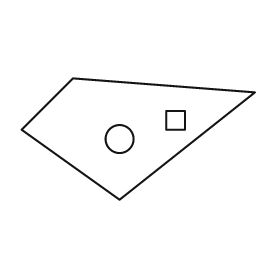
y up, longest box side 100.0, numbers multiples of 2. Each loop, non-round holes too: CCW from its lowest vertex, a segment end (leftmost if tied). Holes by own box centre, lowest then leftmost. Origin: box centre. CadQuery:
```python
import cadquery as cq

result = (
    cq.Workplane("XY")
    .moveTo(-8.0, -26.0)
    .lineTo(50.0, 20.0)
    .lineTo(-28.0, 26.0)
    .lineTo(-50.0, 4.0)
    .close()
    .moveTo(-8.0, 0.0)
    .circle(6.0)
    .moveTo(12.0, 4.0)
    .lineTo(20.0, 4.0)
    .lineTo(20.0, 12.0)
    .lineTo(12.0, 12.0)
    .close()
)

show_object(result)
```